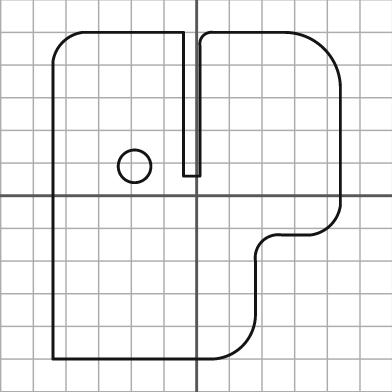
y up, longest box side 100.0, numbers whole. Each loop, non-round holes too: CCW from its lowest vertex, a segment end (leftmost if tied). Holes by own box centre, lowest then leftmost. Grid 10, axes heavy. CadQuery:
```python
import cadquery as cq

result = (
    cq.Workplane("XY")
    .moveTo(-44.0, -50.0)
    .lineTo(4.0, -50.0)
    .threePointArc((14.0, -46.0), (18.0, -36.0))
    .lineTo(18.0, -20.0)
    .threePointArc((20.0, -14.0), (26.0, -12.0))
    .lineTo(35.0, -12.0)
    .threePointArc((41.0, -9.0), (44.0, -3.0))
    .lineTo(44.0, 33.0)
    .threePointArc((39.0, 45.0), (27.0, 50.0))
    .lineTo(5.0, 50.0)
    .threePointArc((2.0, 49.0), (1.0, 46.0))
    .lineTo(1.0, 6.0)
    .lineTo(-4.0, 6.0)
    .lineTo(-4.0, 50.0)
    .lineTo(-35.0, 50.0)
    .threePointArc((-41.0, 47.0), (-44.0, 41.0))
    .close()
    .moveTo(-19.0, 9.0)
    .circle(5.0)
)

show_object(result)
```